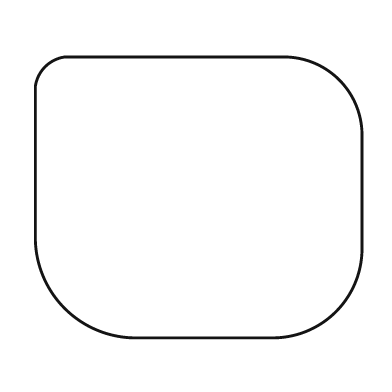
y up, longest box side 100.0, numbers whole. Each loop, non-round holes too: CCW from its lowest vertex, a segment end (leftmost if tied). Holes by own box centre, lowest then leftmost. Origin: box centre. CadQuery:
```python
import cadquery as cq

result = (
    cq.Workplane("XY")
    .moveTo(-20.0, -43.0)
    .lineTo(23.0, -43.0)
    .threePointArc((42.0, -35.0), (50.0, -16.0))
    .lineTo(50.0, 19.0)
    .threePointArc((43.0, 36.0), (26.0, 43.0))
    .lineTo(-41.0, 43.0)
    .threePointArc((-47.0, 40.0), (-50.0, 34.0))
    .lineTo(-50.0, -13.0)
    .threePointArc((-41.0, -34.0), (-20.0, -43.0))
    .close()
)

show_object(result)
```